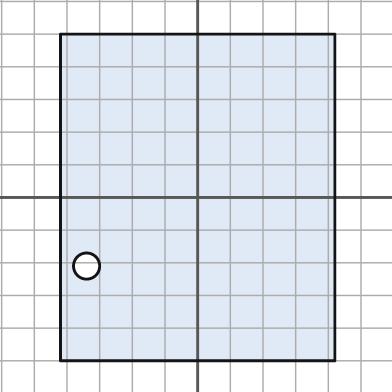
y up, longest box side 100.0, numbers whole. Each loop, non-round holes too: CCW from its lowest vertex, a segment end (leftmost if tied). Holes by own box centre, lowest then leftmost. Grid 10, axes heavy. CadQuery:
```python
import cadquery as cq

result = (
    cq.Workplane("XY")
    .moveTo(-42.0, -50.0)
    .lineTo(42.0, -50.0)
    .lineTo(42.0, 50.0)
    .lineTo(-42.0, 50.0)
    .close()
    .moveTo(-34.0, -21.0)
    .circle(4.0)
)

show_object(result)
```